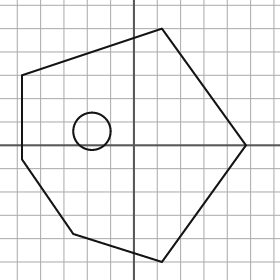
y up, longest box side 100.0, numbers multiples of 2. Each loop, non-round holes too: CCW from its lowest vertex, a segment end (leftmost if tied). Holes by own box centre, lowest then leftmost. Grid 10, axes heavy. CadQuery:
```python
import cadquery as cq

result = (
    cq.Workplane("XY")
    .moveTo(12.0, -50.0)
    .lineTo(48.0, 0.0)
    .lineTo(12.0, 50.0)
    .lineTo(-48.0, 30.0)
    .lineTo(-48.0, -6.0)
    .lineTo(-26.0, -38.0)
    .close()
    .moveTo(-18.0, 6.0)
    .circle(8.0)
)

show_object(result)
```